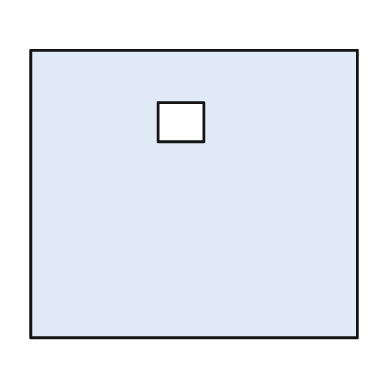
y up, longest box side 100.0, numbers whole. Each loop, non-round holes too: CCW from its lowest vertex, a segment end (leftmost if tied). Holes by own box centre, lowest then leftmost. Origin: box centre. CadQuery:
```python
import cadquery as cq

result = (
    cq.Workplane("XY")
    .moveTo(-50.0, -44.0)
    .lineTo(50.0, -44.0)
    .lineTo(50.0, 44.0)
    .lineTo(-50.0, 44.0)
    .close()
    .moveTo(-11.0, 16.0)
    .lineTo(3.0, 16.0)
    .lineTo(3.0, 28.0)
    .lineTo(-11.0, 28.0)
    .close()
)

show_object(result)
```